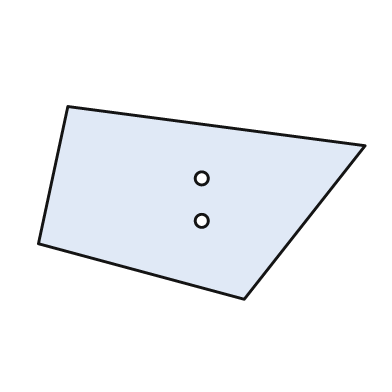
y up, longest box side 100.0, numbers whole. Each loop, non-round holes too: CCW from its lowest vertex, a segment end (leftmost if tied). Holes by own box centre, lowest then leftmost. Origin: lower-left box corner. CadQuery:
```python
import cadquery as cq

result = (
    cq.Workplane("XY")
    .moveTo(63.0, 0.0)
    .lineTo(100.0, 47.0)
    .lineTo(9.0, 59.0)
    .lineTo(0.0, 17.0)
    .close()
    .moveTo(50.0, 24.0)
    .circle(2.0)
    .moveTo(50.0, 37.0)
    .circle(2.0)
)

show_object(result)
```